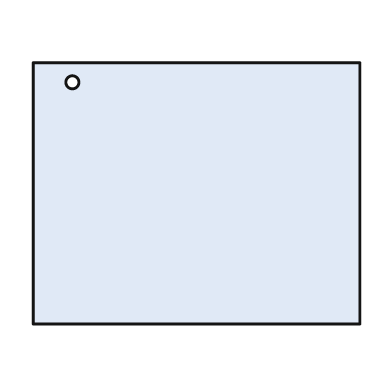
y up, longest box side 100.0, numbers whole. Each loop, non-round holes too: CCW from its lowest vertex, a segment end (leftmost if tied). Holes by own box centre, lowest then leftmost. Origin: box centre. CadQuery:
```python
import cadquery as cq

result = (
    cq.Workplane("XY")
    .moveTo(-50.0, -40.0)
    .lineTo(50.0, -40.0)
    .lineTo(50.0, 40.0)
    .lineTo(-50.0, 40.0)
    .close()
    .moveTo(-38.0, 34.0)
    .circle(2.0)
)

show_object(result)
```